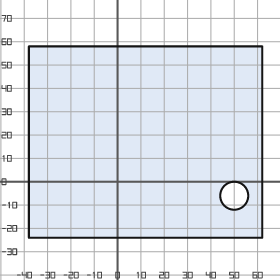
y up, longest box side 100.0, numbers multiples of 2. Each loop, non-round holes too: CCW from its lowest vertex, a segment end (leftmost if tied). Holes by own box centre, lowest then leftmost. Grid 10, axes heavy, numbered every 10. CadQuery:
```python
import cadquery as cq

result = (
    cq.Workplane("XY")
    .moveTo(-38.0, -24.0)
    .lineTo(62.0, -24.0)
    .lineTo(62.0, 58.0)
    .lineTo(-38.0, 58.0)
    .close()
    .moveTo(50.0, -6.0)
    .circle(6.0)
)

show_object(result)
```